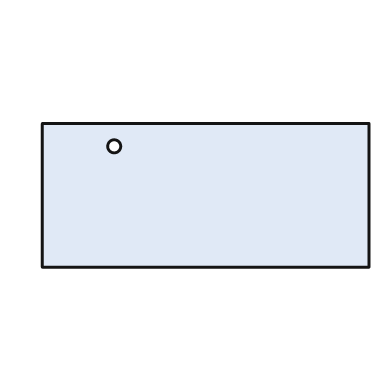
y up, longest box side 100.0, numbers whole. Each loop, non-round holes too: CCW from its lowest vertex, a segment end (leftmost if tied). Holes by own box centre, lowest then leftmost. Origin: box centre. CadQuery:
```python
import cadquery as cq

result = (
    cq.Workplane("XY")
    .moveTo(-50.0, -22.0)
    .lineTo(50.0, -22.0)
    .lineTo(50.0, 22.0)
    .lineTo(-50.0, 22.0)
    .close()
    .moveTo(-28.0, 15.0)
    .circle(2.0)
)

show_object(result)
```